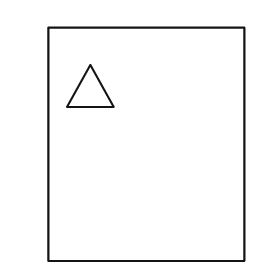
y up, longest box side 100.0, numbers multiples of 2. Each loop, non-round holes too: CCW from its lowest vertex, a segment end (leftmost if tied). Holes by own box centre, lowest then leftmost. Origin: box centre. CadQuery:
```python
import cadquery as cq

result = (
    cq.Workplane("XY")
    .moveTo(-42.0, -50.0)
    .lineTo(42.0, -50.0)
    .lineTo(42.0, 50.0)
    .lineTo(-42.0, 50.0)
    .close()
    .moveTo(-34.0, 16.0)
    .lineTo(-14.0, 16.0)
    .lineTo(-24.0, 34.0)
    .close()
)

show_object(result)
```